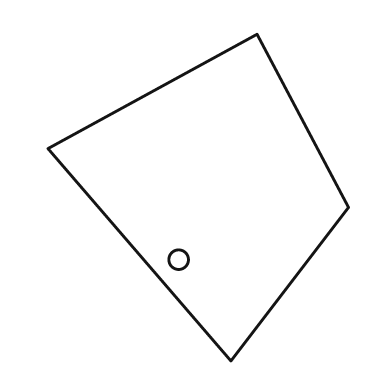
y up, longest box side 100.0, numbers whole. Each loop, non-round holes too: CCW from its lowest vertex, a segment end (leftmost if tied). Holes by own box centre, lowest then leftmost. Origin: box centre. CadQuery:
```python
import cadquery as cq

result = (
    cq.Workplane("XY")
    .moveTo(10.0, -50.0)
    .lineTo(46.0, -3.0)
    .lineTo(18.0, 50.0)
    .lineTo(-46.0, 15.0)
    .close()
    .moveTo(-6.0, -19.0)
    .circle(3.0)
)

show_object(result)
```